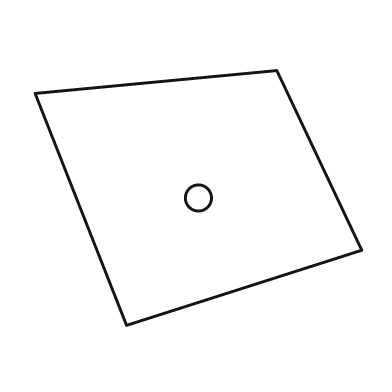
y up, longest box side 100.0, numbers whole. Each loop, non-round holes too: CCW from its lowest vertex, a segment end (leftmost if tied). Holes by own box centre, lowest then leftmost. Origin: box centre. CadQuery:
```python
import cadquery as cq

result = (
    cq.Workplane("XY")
    .moveTo(-22.0, -39.0)
    .lineTo(50.0, -16.0)
    .lineTo(24.0, 39.0)
    .lineTo(-50.0, 32.0)
    .close()
    .moveTo(0.0, 0.0)
    .circle(4.0)
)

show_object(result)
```